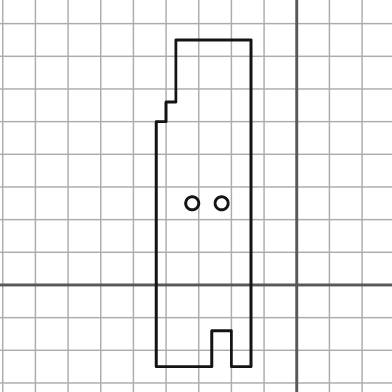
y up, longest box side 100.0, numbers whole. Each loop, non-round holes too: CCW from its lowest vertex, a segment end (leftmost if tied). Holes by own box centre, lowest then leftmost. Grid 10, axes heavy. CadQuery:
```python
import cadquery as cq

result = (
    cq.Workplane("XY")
    .moveTo(-43.0, -25.0)
    .lineTo(-26.0, -25.0)
    .lineTo(-26.0, -14.0)
    .lineTo(-20.0, -14.0)
    .lineTo(-20.0, -25.0)
    .lineTo(-14.0, -25.0)
    .lineTo(-14.0, 75.0)
    .lineTo(-37.0, 75.0)
    .lineTo(-37.0, 56.0)
    .lineTo(-40.0, 56.0)
    .lineTo(-40.0, 50.0)
    .lineTo(-43.0, 50.0)
    .close()
    .moveTo(-32.0, 25.0)
    .circle(2.0)
    .moveTo(-23.0, 25.0)
    .circle(2.0)
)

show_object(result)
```